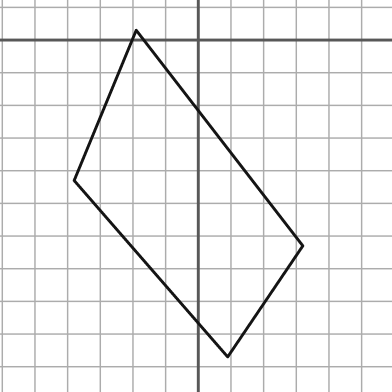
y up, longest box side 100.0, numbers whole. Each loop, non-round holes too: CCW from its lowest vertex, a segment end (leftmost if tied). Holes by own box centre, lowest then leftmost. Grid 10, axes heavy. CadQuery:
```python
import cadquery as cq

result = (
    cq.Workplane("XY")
    .moveTo(9.0, -97.0)
    .lineTo(32.0, -63.0)
    .lineTo(-19.0, 3.0)
    .lineTo(-38.0, -43.0)
    .close()
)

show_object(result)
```